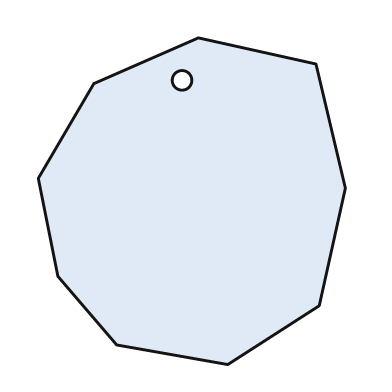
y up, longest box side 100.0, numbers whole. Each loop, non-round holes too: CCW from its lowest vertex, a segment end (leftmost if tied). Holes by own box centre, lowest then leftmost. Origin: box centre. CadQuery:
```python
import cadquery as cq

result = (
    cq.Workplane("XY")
    .moveTo(11.0, -50.0)
    .lineTo(39.0, -32.0)
    .lineTo(47.0, 4.0)
    .lineTo(38.0, 42.0)
    .lineTo(2.0, 50.0)
    .lineTo(-30.0, 36.0)
    .lineTo(-47.0, 7.0)
    .lineTo(-41.0, -23.0)
    .lineTo(-23.0, -44.0)
    .close()
    .moveTo(-3.0, 37.0)
    .circle(3.0)
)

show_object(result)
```